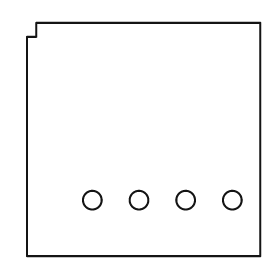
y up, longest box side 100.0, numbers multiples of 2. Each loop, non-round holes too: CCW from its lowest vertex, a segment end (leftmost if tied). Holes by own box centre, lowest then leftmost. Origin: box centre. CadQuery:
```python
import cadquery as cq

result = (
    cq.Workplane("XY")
    .moveTo(-50.0, -50.0)
    .lineTo(50.0, -50.0)
    .lineTo(50.0, 50.0)
    .lineTo(-46.0, 50.0)
    .lineTo(-46.0, 44.0)
    .lineTo(-50.0, 44.0)
    .close()
    .moveTo(-22.0, -26.0)
    .circle(4.0)
    .moveTo(-2.0, -26.0)
    .circle(4.0)
    .moveTo(18.0, -26.0)
    .circle(4.0)
    .moveTo(38.0, -26.0)
    .circle(4.0)
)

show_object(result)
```